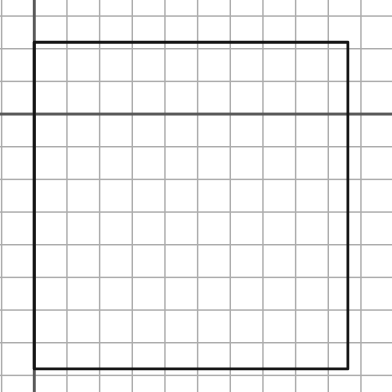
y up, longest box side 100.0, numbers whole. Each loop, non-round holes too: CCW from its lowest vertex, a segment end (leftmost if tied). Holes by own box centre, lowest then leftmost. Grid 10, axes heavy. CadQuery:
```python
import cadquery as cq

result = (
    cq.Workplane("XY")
    .moveTo(0.0, -78.0)
    .lineTo(96.0, -78.0)
    .lineTo(96.0, 22.0)
    .lineTo(0.0, 22.0)
    .close()
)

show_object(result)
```